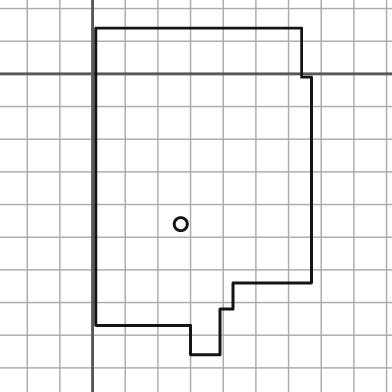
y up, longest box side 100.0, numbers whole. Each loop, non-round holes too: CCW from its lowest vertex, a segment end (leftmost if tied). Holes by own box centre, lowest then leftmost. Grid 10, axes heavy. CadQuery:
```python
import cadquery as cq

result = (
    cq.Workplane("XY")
    .moveTo(30.0, -86.0)
    .lineTo(39.0, -86.0)
    .lineTo(39.0, -72.0)
    .lineTo(43.0, -72.0)
    .lineTo(43.0, -64.0)
    .lineTo(67.0, -64.0)
    .lineTo(67.0, -1.0)
    .lineTo(64.0, -1.0)
    .lineTo(64.0, 14.0)
    .lineTo(1.0, 14.0)
    .lineTo(1.0, -77.0)
    .lineTo(30.0, -77.0)
    .close()
    .moveTo(27.0, -46.0)
    .circle(2.0)
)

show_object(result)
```